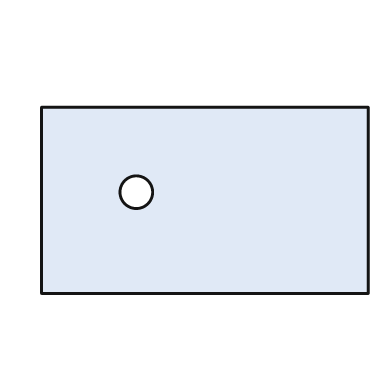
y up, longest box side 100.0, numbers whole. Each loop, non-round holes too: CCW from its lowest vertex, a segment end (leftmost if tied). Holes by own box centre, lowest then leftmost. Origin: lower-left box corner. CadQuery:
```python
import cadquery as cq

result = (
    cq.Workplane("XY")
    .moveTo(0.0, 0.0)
    .lineTo(100.0, 0.0)
    .lineTo(100.0, 57.0)
    .lineTo(0.0, 57.0)
    .close()
    .moveTo(29.0, 31.0)
    .circle(5.0)
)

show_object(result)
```